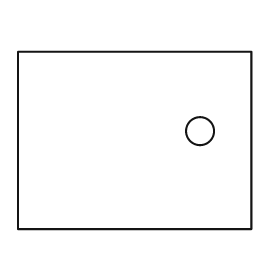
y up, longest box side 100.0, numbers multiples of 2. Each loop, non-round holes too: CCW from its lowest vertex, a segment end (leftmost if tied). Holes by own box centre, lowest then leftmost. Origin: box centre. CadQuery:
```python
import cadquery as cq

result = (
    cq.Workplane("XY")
    .moveTo(-50.0, -38.0)
    .lineTo(50.0, -38.0)
    .lineTo(50.0, 38.0)
    .lineTo(-50.0, 38.0)
    .close()
    .moveTo(28.0, 4.0)
    .circle(6.0)
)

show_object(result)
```